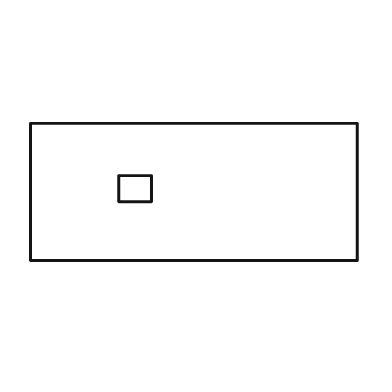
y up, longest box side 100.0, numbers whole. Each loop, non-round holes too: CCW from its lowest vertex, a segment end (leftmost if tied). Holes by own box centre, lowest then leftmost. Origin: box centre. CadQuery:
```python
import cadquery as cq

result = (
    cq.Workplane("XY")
    .moveTo(-50.0, -21.0)
    .lineTo(50.0, -21.0)
    .lineTo(50.0, 21.0)
    .lineTo(-50.0, 21.0)
    .close()
    .moveTo(-23.0, -3.0)
    .lineTo(-13.0, -3.0)
    .lineTo(-13.0, 5.0)
    .lineTo(-23.0, 5.0)
    .close()
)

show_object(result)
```